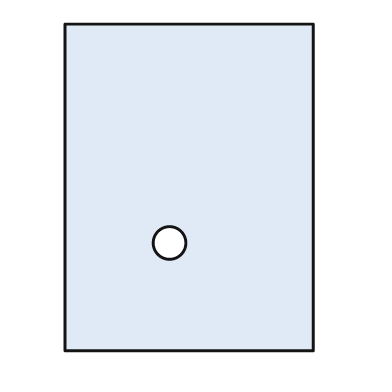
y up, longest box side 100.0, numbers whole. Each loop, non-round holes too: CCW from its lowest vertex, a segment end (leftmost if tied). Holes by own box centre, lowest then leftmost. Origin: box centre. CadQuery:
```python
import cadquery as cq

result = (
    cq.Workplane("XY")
    .moveTo(-38.0, -50.0)
    .lineTo(38.0, -50.0)
    .lineTo(38.0, 50.0)
    .lineTo(-38.0, 50.0)
    .close()
    .moveTo(-6.0, -17.0)
    .circle(5.0)
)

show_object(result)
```